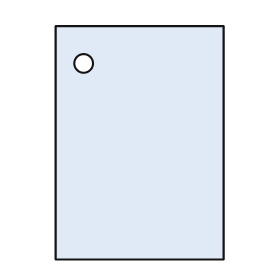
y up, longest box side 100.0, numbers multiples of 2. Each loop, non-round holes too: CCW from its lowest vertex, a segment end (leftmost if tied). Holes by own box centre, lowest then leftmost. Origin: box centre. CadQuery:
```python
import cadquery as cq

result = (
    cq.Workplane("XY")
    .moveTo(-36.0, -50.0)
    .lineTo(36.0, -50.0)
    .lineTo(36.0, 50.0)
    .lineTo(-36.0, 50.0)
    .close()
    .moveTo(-24.0, 34.0)
    .circle(4.0)
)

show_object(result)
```